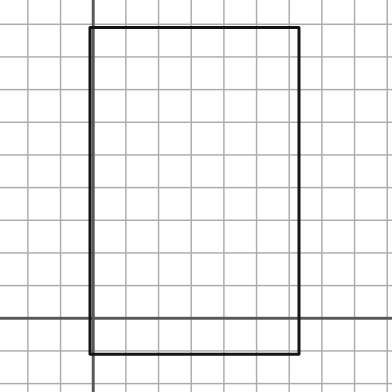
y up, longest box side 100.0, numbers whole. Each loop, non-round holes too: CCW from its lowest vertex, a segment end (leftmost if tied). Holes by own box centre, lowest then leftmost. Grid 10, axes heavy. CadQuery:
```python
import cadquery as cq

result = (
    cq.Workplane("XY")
    .moveTo(-1.0, -11.0)
    .lineTo(63.0, -11.0)
    .lineTo(63.0, 89.0)
    .lineTo(-1.0, 89.0)
    .close()
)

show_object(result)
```